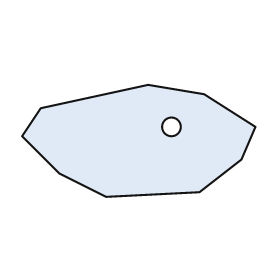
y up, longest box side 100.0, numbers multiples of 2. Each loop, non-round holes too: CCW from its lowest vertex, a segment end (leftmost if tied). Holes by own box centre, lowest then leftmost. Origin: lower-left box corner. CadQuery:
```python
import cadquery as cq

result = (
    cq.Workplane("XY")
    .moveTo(36.0, 0.0)
    .lineTo(76.0, 2.0)
    .lineTo(94.0, 16.0)
    .lineTo(100.0, 30.0)
    .lineTo(78.0, 44.0)
    .lineTo(54.0, 48.0)
    .lineTo(8.0, 38.0)
    .lineTo(0.0, 26.0)
    .lineTo(16.0, 10.0)
    .close()
    .moveTo(64.0, 30.0)
    .circle(4.0)
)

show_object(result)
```